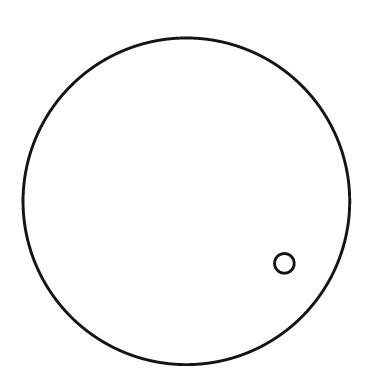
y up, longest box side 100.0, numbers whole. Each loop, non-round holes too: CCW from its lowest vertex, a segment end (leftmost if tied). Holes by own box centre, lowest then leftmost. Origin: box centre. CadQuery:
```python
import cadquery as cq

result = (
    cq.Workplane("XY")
    .moveTo(0.0, 0.0)
    .circle(50.0)
    .moveTo(30.0, -19.0)
    .circle(3.0)
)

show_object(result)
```